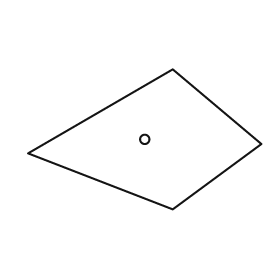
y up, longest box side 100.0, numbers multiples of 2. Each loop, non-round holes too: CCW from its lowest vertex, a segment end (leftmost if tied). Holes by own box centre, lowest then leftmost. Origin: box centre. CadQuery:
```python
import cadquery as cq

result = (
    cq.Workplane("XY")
    .moveTo(12.0, -30.0)
    .lineTo(50.0, -2.0)
    .lineTo(12.0, 30.0)
    .lineTo(-50.0, -6.0)
    .close()
    .moveTo(0.0, 0.0)
    .circle(2.0)
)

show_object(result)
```